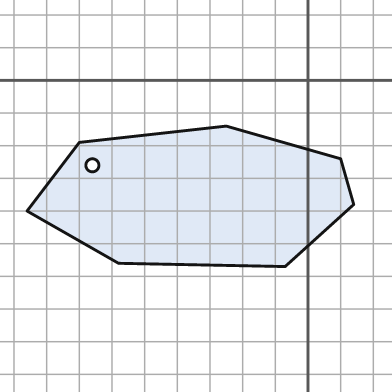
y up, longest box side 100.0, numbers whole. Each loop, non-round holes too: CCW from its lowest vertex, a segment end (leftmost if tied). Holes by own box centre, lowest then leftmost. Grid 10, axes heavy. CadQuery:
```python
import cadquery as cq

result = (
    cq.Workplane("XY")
    .moveTo(-7.0, -57.0)
    .lineTo(14.0, -38.0)
    .lineTo(10.0, -24.0)
    .lineTo(-25.0, -14.0)
    .lineTo(-70.0, -19.0)
    .lineTo(-86.0, -40.0)
    .lineTo(-58.0, -56.0)
    .close()
    .moveTo(-66.0, -26.0)
    .circle(2.0)
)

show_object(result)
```